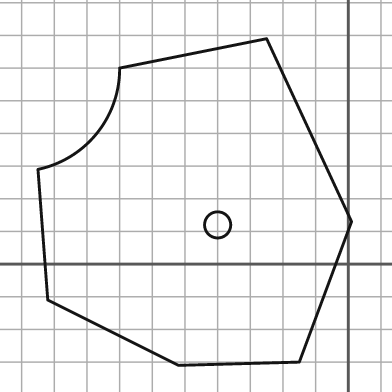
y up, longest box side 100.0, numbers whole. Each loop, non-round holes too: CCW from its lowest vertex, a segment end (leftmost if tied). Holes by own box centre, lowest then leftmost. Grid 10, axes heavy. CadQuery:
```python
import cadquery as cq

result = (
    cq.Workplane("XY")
    .moveTo(-52.0, -31.0)
    .lineTo(-15.0, -30.0)
    .lineTo(1.0, 13.0)
    .lineTo(-25.0, 69.0)
    .lineTo(-70.0, 60.0)
    .threePointArc((-77.0, 40.0), (-95.0, 29.0))
    .lineTo(-92.0, -11.0)
    .close()
    .moveTo(-40.0, 12.0)
    .circle(4.0)
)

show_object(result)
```